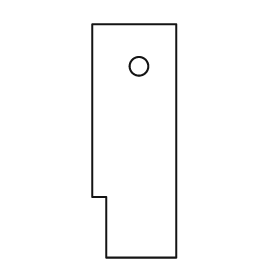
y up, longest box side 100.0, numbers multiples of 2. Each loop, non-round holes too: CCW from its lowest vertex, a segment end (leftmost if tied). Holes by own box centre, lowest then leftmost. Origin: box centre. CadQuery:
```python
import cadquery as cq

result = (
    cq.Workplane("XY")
    .moveTo(-12.0, -50.0)
    .lineTo(18.0, -50.0)
    .lineTo(18.0, 50.0)
    .lineTo(-18.0, 50.0)
    .lineTo(-18.0, -24.0)
    .lineTo(-12.0, -24.0)
    .close()
    .moveTo(2.0, 32.0)
    .circle(4.0)
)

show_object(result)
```